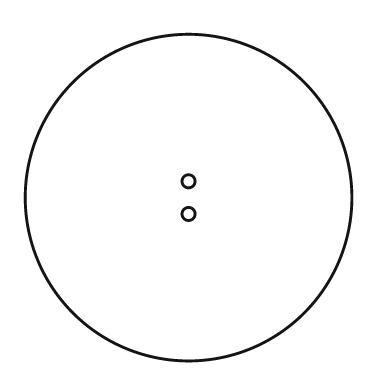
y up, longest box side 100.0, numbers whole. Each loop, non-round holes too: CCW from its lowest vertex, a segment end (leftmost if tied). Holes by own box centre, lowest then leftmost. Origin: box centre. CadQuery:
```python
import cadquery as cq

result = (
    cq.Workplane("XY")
    .moveTo(0.0, 0.0)
    .circle(50.0)
    .moveTo(0.0, -5.0)
    .circle(2.0)
    .moveTo(0.0, 5.0)
    .circle(2.0)
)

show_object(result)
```